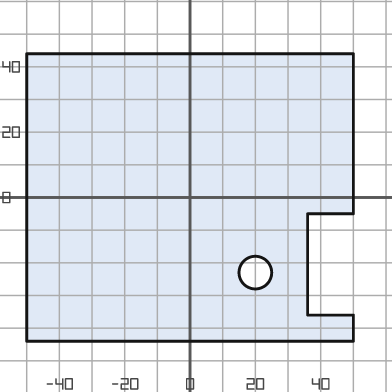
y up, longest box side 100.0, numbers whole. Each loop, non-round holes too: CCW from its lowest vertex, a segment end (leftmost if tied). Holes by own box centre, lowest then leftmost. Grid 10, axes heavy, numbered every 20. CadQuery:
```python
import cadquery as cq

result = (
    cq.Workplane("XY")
    .moveTo(-50.0, -44.0)
    .lineTo(50.0, -44.0)
    .lineTo(50.0, -36.0)
    .lineTo(36.0, -36.0)
    .lineTo(36.0, -5.0)
    .lineTo(50.0, -5.0)
    .lineTo(50.0, 44.0)
    .lineTo(-50.0, 44.0)
    .close()
    .moveTo(20.0, -23.0)
    .circle(5.0)
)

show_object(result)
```